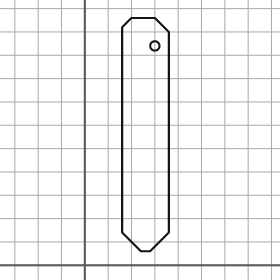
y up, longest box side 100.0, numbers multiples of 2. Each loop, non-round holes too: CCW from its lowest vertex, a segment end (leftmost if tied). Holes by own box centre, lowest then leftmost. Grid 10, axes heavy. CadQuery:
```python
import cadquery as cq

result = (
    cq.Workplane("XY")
    .moveTo(24.0, 6.0)
    .lineTo(28.0, 6.0)
    .lineTo(36.0, 14.0)
    .lineTo(36.0, 100.0)
    .lineTo(30.0, 106.0)
    .lineTo(20.0, 106.0)
    .lineTo(16.0, 102.0)
    .lineTo(16.0, 14.0)
    .close()
    .moveTo(30.0, 94.0)
    .circle(2.0)
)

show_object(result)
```